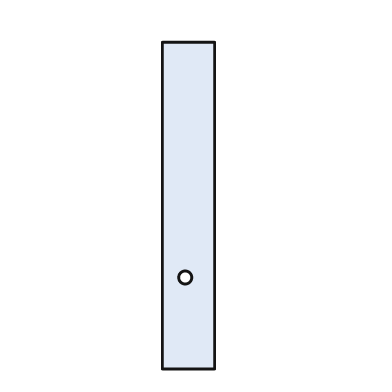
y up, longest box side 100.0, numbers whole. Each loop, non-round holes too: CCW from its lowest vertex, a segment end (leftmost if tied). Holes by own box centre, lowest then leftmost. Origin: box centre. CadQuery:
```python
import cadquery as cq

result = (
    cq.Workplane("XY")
    .moveTo(-8.0, -50.0)
    .lineTo(8.0, -50.0)
    .lineTo(8.0, 50.0)
    .lineTo(-8.0, 50.0)
    .close()
    .moveTo(-1.0, -22.0)
    .circle(2.0)
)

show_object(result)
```